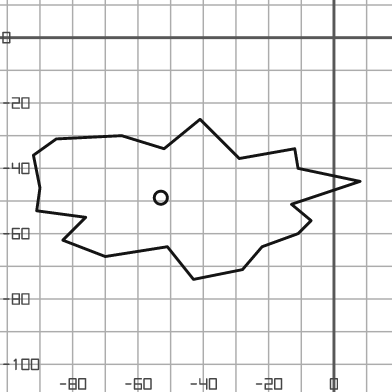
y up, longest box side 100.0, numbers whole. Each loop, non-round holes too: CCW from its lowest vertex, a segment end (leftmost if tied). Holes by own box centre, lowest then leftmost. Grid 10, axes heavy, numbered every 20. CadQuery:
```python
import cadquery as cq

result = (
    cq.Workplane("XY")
    .moveTo(-43.0, -74.0)
    .lineTo(-28.0, -71.0)
    .lineTo(-22.0, -64.0)
    .lineTo(-11.0, -60.0)
    .lineTo(-7.0, -56.0)
    .lineTo(-13.0, -51.0)
    .lineTo(8.0, -44.0)
    .lineTo(-11.0, -40.0)
    .lineTo(-12.0, -34.0)
    .lineTo(-29.0, -37.0)
    .lineTo(-41.0, -25.0)
    .lineTo(-52.0, -34.0)
    .lineTo(-65.0, -30.0)
    .lineTo(-85.0, -31.0)
    .lineTo(-92.0, -36.0)
    .lineTo(-90.0, -46.0)
    .lineTo(-91.0, -53.0)
    .lineTo(-76.0, -55.0)
    .lineTo(-83.0, -62.0)
    .lineTo(-70.0, -67.0)
    .lineTo(-51.0, -64.0)
    .close()
    .moveTo(-53.0, -49.0)
    .circle(2.0)
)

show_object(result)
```